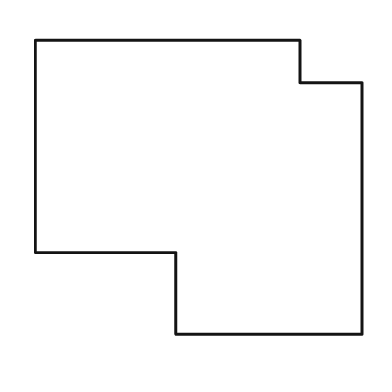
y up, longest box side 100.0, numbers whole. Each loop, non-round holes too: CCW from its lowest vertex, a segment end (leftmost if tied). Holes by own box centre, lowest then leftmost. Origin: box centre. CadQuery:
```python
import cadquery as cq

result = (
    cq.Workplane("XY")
    .moveTo(-7.0, -45.0)
    .lineTo(50.0, -45.0)
    .lineTo(50.0, 32.0)
    .lineTo(31.0, 32.0)
    .lineTo(31.0, 45.0)
    .lineTo(-50.0, 45.0)
    .lineTo(-50.0, -20.0)
    .lineTo(-7.0, -20.0)
    .close()
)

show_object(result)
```